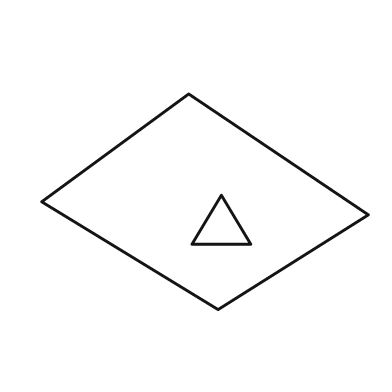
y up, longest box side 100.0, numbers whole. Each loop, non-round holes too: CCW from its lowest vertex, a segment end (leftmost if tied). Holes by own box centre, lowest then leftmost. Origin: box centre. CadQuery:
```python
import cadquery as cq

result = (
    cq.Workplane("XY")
    .moveTo(4.0, -33.0)
    .lineTo(50.0, -4.0)
    .lineTo(-5.0, 33.0)
    .lineTo(-50.0, 0.0)
    .close()
    .moveTo(-4.0, -13.0)
    .lineTo(14.0, -13.0)
    .lineTo(5.0, 2.0)
    .close()
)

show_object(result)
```